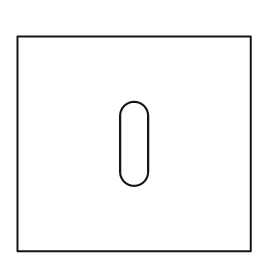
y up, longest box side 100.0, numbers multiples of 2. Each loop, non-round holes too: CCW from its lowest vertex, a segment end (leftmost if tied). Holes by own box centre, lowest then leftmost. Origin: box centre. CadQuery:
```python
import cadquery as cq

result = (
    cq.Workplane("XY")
    .moveTo(-50.0, -46.0)
    .lineTo(50.0, -46.0)
    .lineTo(50.0, 46.0)
    .lineTo(-50.0, 46.0)
    .close()
    .moveTo(-6.0, -12.0)
    .threePointArc((0.0, -18.0), (6.0, -12.0))
    .lineTo(6.0, 12.0)
    .threePointArc((0.0, 18.0), (-6.0, 12.0))
    .close()
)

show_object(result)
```